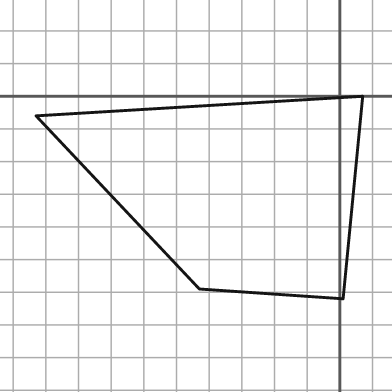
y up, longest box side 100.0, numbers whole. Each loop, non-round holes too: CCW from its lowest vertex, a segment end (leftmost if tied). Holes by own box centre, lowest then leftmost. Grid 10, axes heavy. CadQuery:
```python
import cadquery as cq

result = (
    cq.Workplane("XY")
    .moveTo(1.0, -62.0)
    .lineTo(7.0, 0.0)
    .lineTo(-93.0, -6.0)
    .lineTo(-43.0, -59.0)
    .close()
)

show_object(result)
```